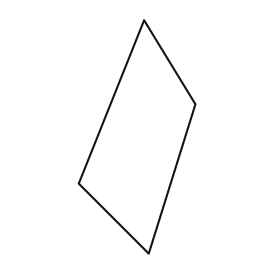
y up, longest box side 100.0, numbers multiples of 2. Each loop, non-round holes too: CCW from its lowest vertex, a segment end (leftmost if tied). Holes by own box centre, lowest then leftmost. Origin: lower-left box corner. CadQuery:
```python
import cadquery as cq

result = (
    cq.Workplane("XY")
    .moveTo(30.0, 0.0)
    .lineTo(50.0, 64.0)
    .lineTo(28.0, 100.0)
    .lineTo(0.0, 30.0)
    .close()
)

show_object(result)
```